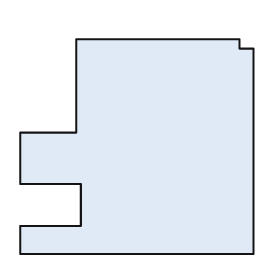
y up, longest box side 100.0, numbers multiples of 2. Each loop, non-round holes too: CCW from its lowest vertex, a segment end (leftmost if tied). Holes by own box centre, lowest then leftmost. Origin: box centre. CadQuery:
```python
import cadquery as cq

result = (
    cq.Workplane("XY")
    .moveTo(-50.0, -46.0)
    .lineTo(50.0, -46.0)
    .lineTo(50.0, 42.0)
    .lineTo(44.0, 42.0)
    .lineTo(44.0, 46.0)
    .lineTo(-26.0, 46.0)
    .lineTo(-26.0, 6.0)
    .lineTo(-50.0, 6.0)
    .lineTo(-50.0, -16.0)
    .lineTo(-24.0, -16.0)
    .lineTo(-24.0, -34.0)
    .lineTo(-50.0, -34.0)
    .close()
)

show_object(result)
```